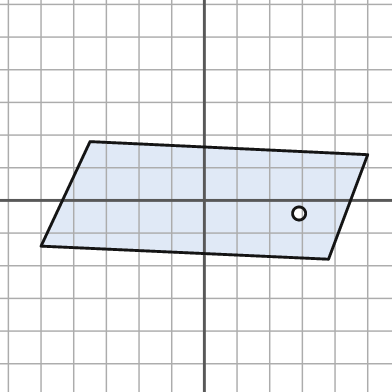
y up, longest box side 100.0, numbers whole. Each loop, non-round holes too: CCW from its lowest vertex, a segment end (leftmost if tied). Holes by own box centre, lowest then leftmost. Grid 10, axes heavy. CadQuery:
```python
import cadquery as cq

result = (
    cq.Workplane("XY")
    .moveTo(38.0, -18.0)
    .lineTo(50.0, 14.0)
    .lineTo(-35.0, 18.0)
    .lineTo(-50.0, -14.0)
    .close()
    .moveTo(29.0, -4.0)
    .circle(2.0)
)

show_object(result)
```